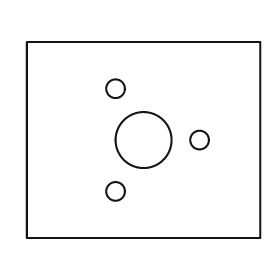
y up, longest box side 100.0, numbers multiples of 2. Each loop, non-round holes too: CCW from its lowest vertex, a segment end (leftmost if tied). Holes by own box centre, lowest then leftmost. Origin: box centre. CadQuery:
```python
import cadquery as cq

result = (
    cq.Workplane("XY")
    .moveTo(-50.0, -42.0)
    .lineTo(50.0, -42.0)
    .lineTo(50.0, 42.0)
    .lineTo(-50.0, 42.0)
    .close()
    .moveTo(-12.0, -22.0)
    .circle(4.0)
    .moveTo(0.0, 0.0)
    .circle(12.0)
    .moveTo(24.0, 0.0)
    .circle(4.0)
    .moveTo(-12.0, 22.0)
    .circle(4.0)
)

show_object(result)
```